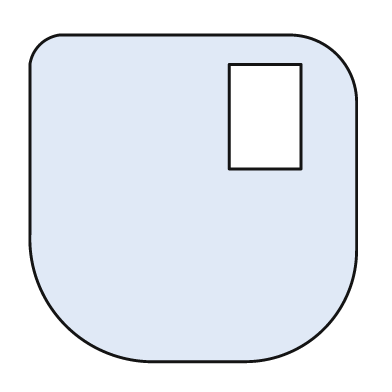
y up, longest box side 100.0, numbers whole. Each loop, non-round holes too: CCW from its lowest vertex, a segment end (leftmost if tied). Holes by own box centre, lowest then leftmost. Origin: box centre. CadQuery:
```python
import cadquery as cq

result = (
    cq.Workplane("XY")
    .moveTo(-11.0, -50.0)
    .lineTo(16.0, -50.0)
    .threePointArc((40.0, -40.0), (50.0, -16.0))
    .lineTo(50.0, 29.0)
    .threePointArc((44.0, 44.0), (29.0, 50.0))
    .lineTo(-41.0, 50.0)
    .threePointArc((-47.0, 47.0), (-50.0, 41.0))
    .lineTo(-50.0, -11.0)
    .threePointArc((-39.0, -39.0), (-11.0, -50.0))
    .close()
    .moveTo(11.0, 9.0)
    .lineTo(33.0, 9.0)
    .lineTo(33.0, 41.0)
    .lineTo(11.0, 41.0)
    .close()
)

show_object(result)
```